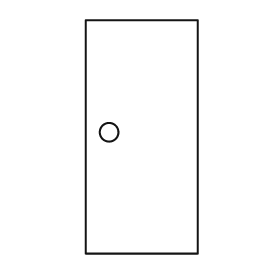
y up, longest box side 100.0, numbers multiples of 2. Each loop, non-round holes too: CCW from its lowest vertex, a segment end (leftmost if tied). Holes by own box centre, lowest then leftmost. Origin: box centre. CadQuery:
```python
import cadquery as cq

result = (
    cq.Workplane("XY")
    .moveTo(-24.0, -50.0)
    .lineTo(24.0, -50.0)
    .lineTo(24.0, 50.0)
    .lineTo(-24.0, 50.0)
    .close()
    .moveTo(-14.0, 2.0)
    .circle(4.0)
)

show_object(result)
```